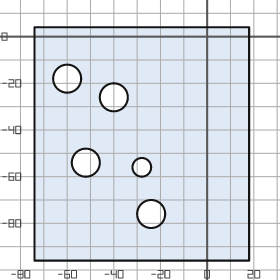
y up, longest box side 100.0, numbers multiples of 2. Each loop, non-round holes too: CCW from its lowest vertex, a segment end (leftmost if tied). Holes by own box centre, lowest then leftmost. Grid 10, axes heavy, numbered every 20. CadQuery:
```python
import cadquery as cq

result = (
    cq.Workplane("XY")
    .moveTo(-74.0, -96.0)
    .lineTo(18.0, -96.0)
    .lineTo(18.0, 4.0)
    .lineTo(-74.0, 4.0)
    .close()
    .moveTo(-24.0, -76.0)
    .circle(6.0)
    .moveTo(-28.0, -56.0)
    .circle(4.0)
    .moveTo(-52.0, -54.0)
    .circle(6.0)
    .moveTo(-40.0, -26.0)
    .circle(6.0)
    .moveTo(-60.0, -18.0)
    .circle(6.0)
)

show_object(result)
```